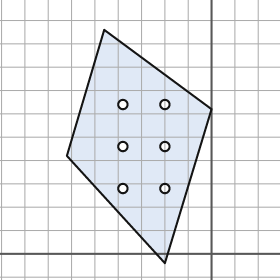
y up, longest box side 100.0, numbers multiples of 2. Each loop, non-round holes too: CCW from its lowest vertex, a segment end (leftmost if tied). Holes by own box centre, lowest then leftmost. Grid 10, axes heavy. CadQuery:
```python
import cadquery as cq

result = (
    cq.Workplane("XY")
    .moveTo(-20.0, -4.0)
    .lineTo(0.0, 62.0)
    .lineTo(-46.0, 96.0)
    .lineTo(-62.0, 42.0)
    .close()
    .moveTo(-38.0, 28.0)
    .circle(2.0)
    .moveTo(-20.0, 28.0)
    .circle(2.0)
    .moveTo(-38.0, 46.0)
    .circle(2.0)
    .moveTo(-20.0, 46.0)
    .circle(2.0)
    .moveTo(-38.0, 64.0)
    .circle(2.0)
    .moveTo(-20.0, 64.0)
    .circle(2.0)
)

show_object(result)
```